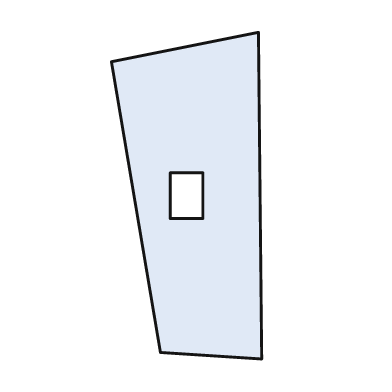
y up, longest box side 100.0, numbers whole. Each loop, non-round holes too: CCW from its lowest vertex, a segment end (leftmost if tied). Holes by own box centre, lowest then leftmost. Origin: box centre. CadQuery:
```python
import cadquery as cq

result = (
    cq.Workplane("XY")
    .moveTo(23.0, -50.0)
    .lineTo(22.0, 50.0)
    .lineTo(-23.0, 41.0)
    .lineTo(-8.0, -48.0)
    .close()
    .moveTo(-5.0, -7.0)
    .lineTo(5.0, -7.0)
    .lineTo(5.0, 7.0)
    .lineTo(-5.0, 7.0)
    .close()
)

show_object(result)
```